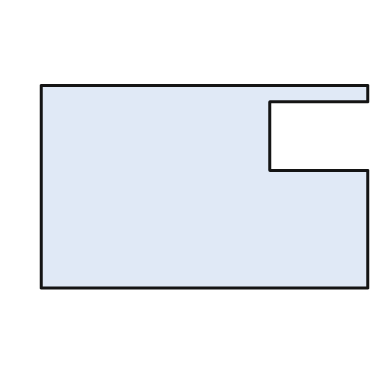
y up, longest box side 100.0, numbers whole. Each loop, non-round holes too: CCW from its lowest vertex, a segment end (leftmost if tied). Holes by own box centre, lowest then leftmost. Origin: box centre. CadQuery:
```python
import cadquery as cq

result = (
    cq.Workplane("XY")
    .moveTo(-50.0, -31.0)
    .lineTo(50.0, -31.0)
    .lineTo(50.0, 5.0)
    .lineTo(20.0, 5.0)
    .lineTo(20.0, 26.0)
    .lineTo(50.0, 26.0)
    .lineTo(50.0, 31.0)
    .lineTo(-50.0, 31.0)
    .close()
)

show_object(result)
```